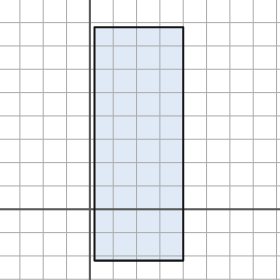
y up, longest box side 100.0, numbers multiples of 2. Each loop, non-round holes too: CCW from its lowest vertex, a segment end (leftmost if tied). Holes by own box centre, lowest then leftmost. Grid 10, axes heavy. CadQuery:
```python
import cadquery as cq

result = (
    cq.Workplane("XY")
    .moveTo(2.0, -22.0)
    .lineTo(40.0, -22.0)
    .lineTo(40.0, 78.0)
    .lineTo(2.0, 78.0)
    .close()
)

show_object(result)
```